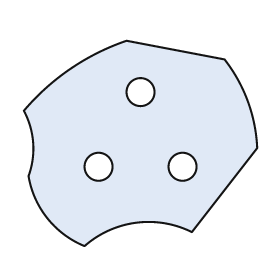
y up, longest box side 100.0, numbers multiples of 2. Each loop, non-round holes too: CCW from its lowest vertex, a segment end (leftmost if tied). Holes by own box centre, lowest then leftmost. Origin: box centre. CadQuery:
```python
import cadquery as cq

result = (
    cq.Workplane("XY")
    .moveTo(-24.0, -44.0)
    .threePointArc((-2.0, -34.0), (22.0, -38.0))
    .lineTo(50.0, -2.0)
    .threePointArc((46.0, 18.0), (36.0, 36.0))
    .lineTo(-6.0, 44.0)
    .threePointArc((-30.0, 32.0), (-50.0, 14.0))
    .threePointArc((-46.0, 0.0), (-48.0, -14.0))
    .threePointArc((-40.0, -32.0), (-24.0, -44.0))
    .close()
    .moveTo(-18.0, -10.0)
    .circle(6.0)
    .moveTo(18.0, -10.0)
    .circle(6.0)
    .moveTo(0.0, 22.0)
    .circle(6.0)
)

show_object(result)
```